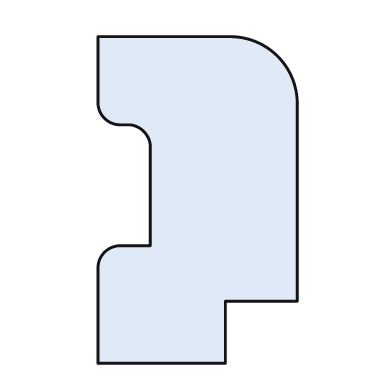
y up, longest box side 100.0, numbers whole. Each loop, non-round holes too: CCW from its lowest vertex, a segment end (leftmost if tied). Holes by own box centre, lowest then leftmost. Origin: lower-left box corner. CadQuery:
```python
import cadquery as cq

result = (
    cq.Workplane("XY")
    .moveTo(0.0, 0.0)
    .lineTo(39.0, 0.0)
    .lineTo(39.0, 19.0)
    .lineTo(61.0, 19.0)
    .lineTo(61.0, 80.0)
    .threePointArc((55.0, 94.0), (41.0, 100.0))
    .lineTo(0.0, 100.0)
    .lineTo(0.0, 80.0)
    .threePointArc((2.0, 75.0), (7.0, 73.0))
    .lineTo(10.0, 73.0)
    .threePointArc((14.0, 71.0), (16.0, 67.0))
    .lineTo(16.0, 36.0)
    .lineTo(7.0, 36.0)
    .threePointArc((2.0, 34.0), (0.0, 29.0))
    .close()
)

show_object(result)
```